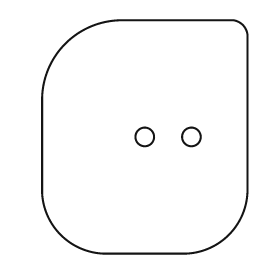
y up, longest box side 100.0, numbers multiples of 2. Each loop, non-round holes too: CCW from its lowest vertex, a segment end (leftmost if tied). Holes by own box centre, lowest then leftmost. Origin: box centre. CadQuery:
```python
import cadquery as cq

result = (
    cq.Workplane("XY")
    .moveTo(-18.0, -50.0)
    .lineTo(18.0, -50.0)
    .threePointArc((36.0, -42.0), (44.0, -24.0))
    .lineTo(44.0, 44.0)
    .threePointArc((42.0, 48.0), (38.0, 50.0))
    .lineTo(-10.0, 50.0)
    .threePointArc((-34.0, 40.0), (-44.0, 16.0))
    .lineTo(-44.0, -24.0)
    .threePointArc((-36.0, -42.0), (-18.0, -50.0))
    .close()
    .moveTo(0.0, 0.0)
    .circle(4.0)
    .moveTo(20.0, 0.0)
    .circle(4.0)
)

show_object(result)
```